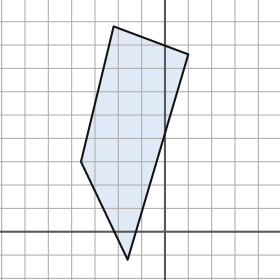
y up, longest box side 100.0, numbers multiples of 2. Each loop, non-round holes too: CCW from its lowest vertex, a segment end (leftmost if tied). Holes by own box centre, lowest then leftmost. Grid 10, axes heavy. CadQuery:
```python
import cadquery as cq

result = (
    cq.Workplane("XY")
    .moveTo(-16.0, -12.0)
    .lineTo(10.0, 76.0)
    .lineTo(-22.0, 88.0)
    .lineTo(-36.0, 30.0)
    .close()
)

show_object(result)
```